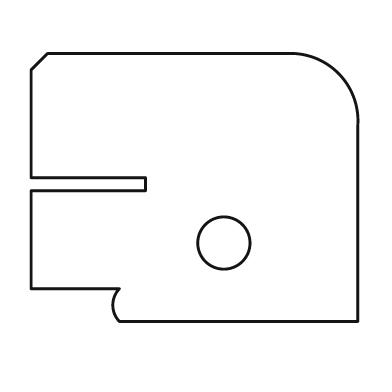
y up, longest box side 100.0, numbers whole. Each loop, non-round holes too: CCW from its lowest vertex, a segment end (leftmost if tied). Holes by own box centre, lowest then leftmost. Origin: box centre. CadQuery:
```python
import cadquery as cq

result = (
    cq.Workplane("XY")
    .moveTo(-23.0, -41.0)
    .lineTo(50.0, -41.0)
    .lineTo(50.0, 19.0)
    .threePointArc((44.0, 35.0), (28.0, 41.0))
    .lineTo(-45.0, 41.0)
    .lineTo(-50.0, 36.0)
    .lineTo(-50.0, 3.0)
    .lineTo(-15.0, 3.0)
    .lineTo(-15.0, -1.0)
    .lineTo(-50.0, -1.0)
    .lineTo(-50.0, -31.0)
    .lineTo(-23.0, -31.0)
    .threePointArc((-25.0, -36.0), (-23.0, -41.0))
    .close()
    .moveTo(9.0, -17.0)
    .circle(8.0)
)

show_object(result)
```